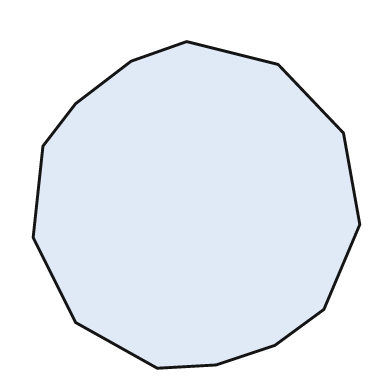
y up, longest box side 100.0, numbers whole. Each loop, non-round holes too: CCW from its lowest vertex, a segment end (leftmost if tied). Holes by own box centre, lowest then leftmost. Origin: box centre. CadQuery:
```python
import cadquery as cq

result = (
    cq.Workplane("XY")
    .moveTo(-12.0, -50.0)
    .lineTo(6.0, -49.0)
    .lineTo(24.0, -43.0)
    .lineTo(39.0, -32.0)
    .lineTo(50.0, -6.0)
    .lineTo(45.0, 22.0)
    .lineTo(25.0, 43.0)
    .lineTo(-3.0, 50.0)
    .lineTo(-20.0, 44.0)
    .lineTo(-37.0, 31.0)
    .lineTo(-47.0, 18.0)
    .lineTo(-50.0, -10.0)
    .lineTo(-37.0, -36.0)
    .close()
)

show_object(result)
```